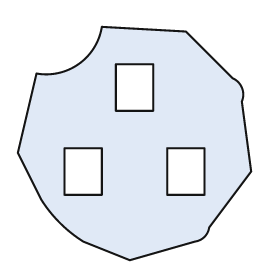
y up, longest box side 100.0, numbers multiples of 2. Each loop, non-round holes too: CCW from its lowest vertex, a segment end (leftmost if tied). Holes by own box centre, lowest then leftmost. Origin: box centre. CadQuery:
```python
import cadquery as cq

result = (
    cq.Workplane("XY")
    .moveTo(-2.0, -50.0)
    .lineTo(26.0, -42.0)
    .threePointArc((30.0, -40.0), (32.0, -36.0))
    .lineTo(50.0, -12.0)
    .lineTo(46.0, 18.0)
    .threePointArc((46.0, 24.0), (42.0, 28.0))
    .lineTo(22.0, 48.0)
    .lineTo(-14.0, 50.0)
    .threePointArc((-24.0, 34.0), (-42.0, 30.0))
    .lineTo(-50.0, -4.0)
    .lineTo(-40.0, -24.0)
    .threePointArc((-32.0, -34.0), (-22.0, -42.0))
    .close()
    .moveTo(-30.0, -22.0)
    .lineTo(-14.0, -22.0)
    .lineTo(-14.0, -2.0)
    .lineTo(-30.0, -2.0)
    .close()
    .moveTo(14.0, -22.0)
    .lineTo(30.0, -22.0)
    .lineTo(30.0, -2.0)
    .lineTo(14.0, -2.0)
    .close()
    .moveTo(-8.0, 14.0)
    .lineTo(8.0, 14.0)
    .lineTo(8.0, 34.0)
    .lineTo(-8.0, 34.0)
    .close()
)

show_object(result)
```